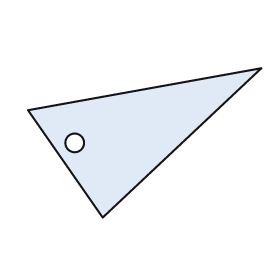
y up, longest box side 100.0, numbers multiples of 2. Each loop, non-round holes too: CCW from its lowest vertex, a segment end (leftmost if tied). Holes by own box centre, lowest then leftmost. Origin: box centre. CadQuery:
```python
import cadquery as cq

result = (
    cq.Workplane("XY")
    .moveTo(-18.0, -32.0)
    .lineTo(50.0, 32.0)
    .lineTo(-50.0, 14.0)
    .close()
    .moveTo(-30.0, 0.0)
    .circle(4.0)
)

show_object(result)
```